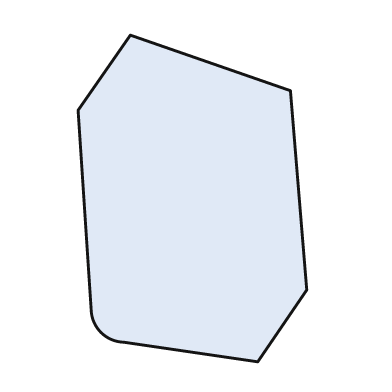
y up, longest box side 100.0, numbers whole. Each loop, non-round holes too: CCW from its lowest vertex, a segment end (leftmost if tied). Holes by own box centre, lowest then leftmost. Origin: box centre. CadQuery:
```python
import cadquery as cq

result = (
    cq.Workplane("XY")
    .moveTo(20.0, -50.0)
    .lineTo(35.0, -28.0)
    .lineTo(30.0, 33.0)
    .lineTo(-19.0, 50.0)
    .lineTo(-35.0, 27.0)
    .lineTo(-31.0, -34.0)
    .threePointArc((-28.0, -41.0), (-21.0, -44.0))
    .close()
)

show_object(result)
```